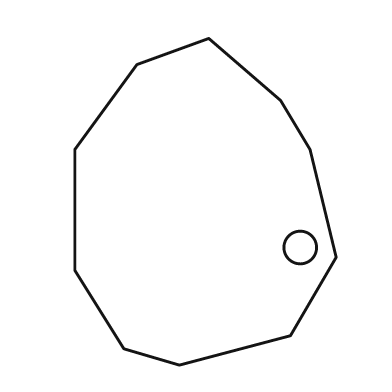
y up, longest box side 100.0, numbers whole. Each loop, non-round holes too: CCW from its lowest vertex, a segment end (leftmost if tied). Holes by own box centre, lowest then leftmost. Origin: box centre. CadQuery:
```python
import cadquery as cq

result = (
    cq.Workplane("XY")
    .moveTo(-8.0, -50.0)
    .lineTo(26.0, -41.0)
    .lineTo(40.0, -17.0)
    .lineTo(32.0, 16.0)
    .lineTo(23.0, 31.0)
    .lineTo(1.0, 50.0)
    .lineTo(-21.0, 42.0)
    .lineTo(-40.0, 16.0)
    .lineTo(-40.0, -21.0)
    .lineTo(-25.0, -45.0)
    .close()
    .moveTo(29.0, -14.0)
    .circle(5.0)
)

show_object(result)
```